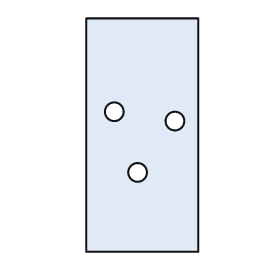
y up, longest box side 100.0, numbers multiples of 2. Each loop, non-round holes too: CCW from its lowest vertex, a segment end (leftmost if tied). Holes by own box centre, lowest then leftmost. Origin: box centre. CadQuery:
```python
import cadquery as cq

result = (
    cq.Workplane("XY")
    .moveTo(-24.0, -50.0)
    .lineTo(24.0, -50.0)
    .lineTo(24.0, 50.0)
    .lineTo(-24.0, 50.0)
    .close()
    .moveTo(-2.0, -16.0)
    .circle(4.0)
    .moveTo(14.0, 6.0)
    .circle(4.0)
    .moveTo(-12.0, 10.0)
    .circle(4.0)
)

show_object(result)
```